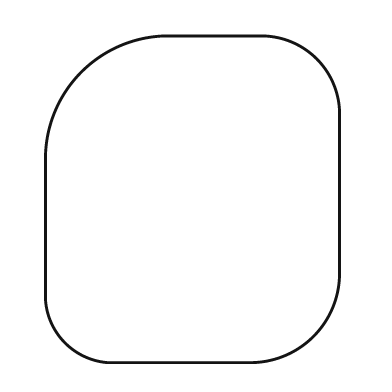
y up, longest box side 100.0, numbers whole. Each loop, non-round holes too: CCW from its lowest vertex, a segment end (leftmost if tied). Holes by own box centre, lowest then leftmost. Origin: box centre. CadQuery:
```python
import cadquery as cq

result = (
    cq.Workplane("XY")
    .moveTo(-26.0, -50.0)
    .lineTo(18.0, -50.0)
    .threePointArc((37.0, -42.0), (45.0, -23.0))
    .lineTo(45.0, 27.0)
    .threePointArc((38.0, 43.0), (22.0, 50.0))
    .lineTo(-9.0, 50.0)
    .threePointArc((-34.0, 39.0), (-45.0, 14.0))
    .lineTo(-45.0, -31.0)
    .threePointArc((-39.0, -44.0), (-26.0, -50.0))
    .close()
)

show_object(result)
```